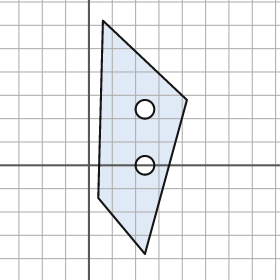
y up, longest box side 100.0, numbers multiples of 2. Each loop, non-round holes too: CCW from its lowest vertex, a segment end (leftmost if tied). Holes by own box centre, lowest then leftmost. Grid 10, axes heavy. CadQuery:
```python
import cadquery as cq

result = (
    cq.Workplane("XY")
    .moveTo(24.0, -38.0)
    .lineTo(42.0, 28.0)
    .lineTo(6.0, 62.0)
    .lineTo(4.0, -14.0)
    .close()
    .moveTo(24.0, 0.0)
    .circle(4.0)
    .moveTo(24.0, 24.0)
    .circle(4.0)
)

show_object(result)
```